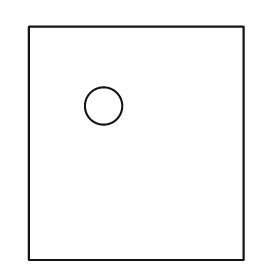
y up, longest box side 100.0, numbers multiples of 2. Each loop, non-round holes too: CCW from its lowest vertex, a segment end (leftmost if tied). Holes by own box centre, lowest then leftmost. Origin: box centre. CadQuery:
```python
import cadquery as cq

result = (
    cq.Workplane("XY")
    .moveTo(-46.0, -50.0)
    .lineTo(46.0, -50.0)
    .lineTo(46.0, 50.0)
    .lineTo(-46.0, 50.0)
    .close()
    .moveTo(-14.0, 16.0)
    .circle(8.0)
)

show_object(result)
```